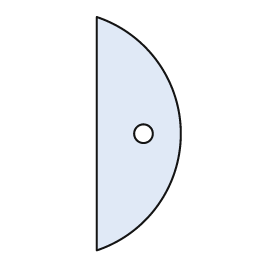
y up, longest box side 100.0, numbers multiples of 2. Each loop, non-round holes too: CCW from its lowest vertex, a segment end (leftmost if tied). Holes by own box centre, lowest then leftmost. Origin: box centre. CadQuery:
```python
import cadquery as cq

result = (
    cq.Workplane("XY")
    .moveTo(-18.0, -50.0)
    .threePointArc((18.0, 0.0), (-18.0, 50.0))
    .close()
    .moveTo(2.0, 0.0)
    .circle(4.0)
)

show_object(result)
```